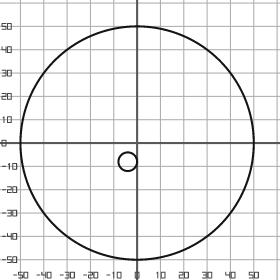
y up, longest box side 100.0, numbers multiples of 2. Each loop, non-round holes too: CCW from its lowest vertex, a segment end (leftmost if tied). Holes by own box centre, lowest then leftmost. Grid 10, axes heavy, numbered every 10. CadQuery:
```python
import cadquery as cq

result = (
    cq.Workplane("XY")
    .moveTo(0.0, 0.0)
    .circle(50.0)
    .moveTo(-4.0, -8.0)
    .circle(4.0)
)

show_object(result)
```